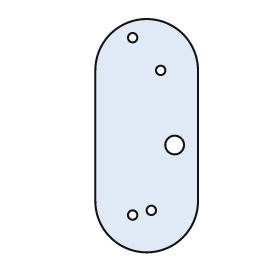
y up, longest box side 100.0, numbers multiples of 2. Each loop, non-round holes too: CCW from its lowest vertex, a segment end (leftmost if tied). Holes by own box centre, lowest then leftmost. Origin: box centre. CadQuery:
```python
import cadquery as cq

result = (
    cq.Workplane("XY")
    .moveTo(-22.0, -28.0)
    .threePointArc((0.0, -50.0), (22.0, -28.0))
    .lineTo(22.0, 28.0)
    .threePointArc((0.0, 50.0), (-22.0, 28.0))
    .close()
    .moveTo(-6.0, -34.0)
    .circle(2.0)
    .moveTo(2.0, -32.0)
    .circle(2.0)
    .moveTo(12.0, -4.0)
    .circle(4.0)
    .moveTo(6.0, 28.0)
    .circle(2.0)
    .moveTo(-6.0, 42.0)
    .circle(2.0)
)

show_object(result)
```